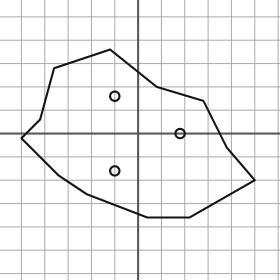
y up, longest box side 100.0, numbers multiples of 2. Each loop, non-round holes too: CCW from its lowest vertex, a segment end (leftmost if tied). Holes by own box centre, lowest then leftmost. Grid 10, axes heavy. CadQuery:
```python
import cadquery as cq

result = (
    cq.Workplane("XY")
    .moveTo(4.0, -36.0)
    .lineTo(22.0, -36.0)
    .lineTo(50.0, -20.0)
    .lineTo(38.0, -6.0)
    .lineTo(28.0, 14.0)
    .lineTo(8.0, 20.0)
    .lineTo(-12.0, 36.0)
    .lineTo(-36.0, 28.0)
    .lineTo(-42.0, 6.0)
    .lineTo(-50.0, -2.0)
    .lineTo(-34.0, -18.0)
    .lineTo(-22.0, -26.0)
    .close()
    .moveTo(-10.0, -16.0)
    .circle(2.0)
    .moveTo(18.0, 0.0)
    .circle(2.0)
    .moveTo(-10.0, 16.0)
    .circle(2.0)
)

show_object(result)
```